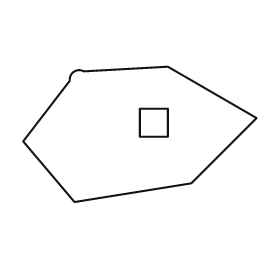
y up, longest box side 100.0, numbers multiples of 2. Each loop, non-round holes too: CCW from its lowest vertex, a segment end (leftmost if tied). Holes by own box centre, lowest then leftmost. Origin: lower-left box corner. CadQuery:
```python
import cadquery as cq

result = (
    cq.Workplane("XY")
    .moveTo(22.0, 0.0)
    .lineTo(72.0, 8.0)
    .lineTo(100.0, 36.0)
    .lineTo(62.0, 58.0)
    .lineTo(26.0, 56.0)
    .threePointArc((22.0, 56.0), (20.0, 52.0))
    .lineTo(0.0, 26.0)
    .close()
    .moveTo(50.0, 28.0)
    .lineTo(62.0, 28.0)
    .lineTo(62.0, 40.0)
    .lineTo(50.0, 40.0)
    .close()
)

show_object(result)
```